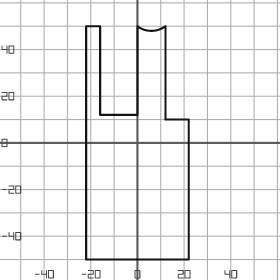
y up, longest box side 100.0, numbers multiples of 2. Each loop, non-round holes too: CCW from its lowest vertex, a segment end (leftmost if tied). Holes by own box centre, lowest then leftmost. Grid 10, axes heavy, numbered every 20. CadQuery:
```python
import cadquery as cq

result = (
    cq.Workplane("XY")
    .moveTo(-22.0, -50.0)
    .lineTo(22.0, -50.0)
    .lineTo(22.0, 10.0)
    .lineTo(12.0, 10.0)
    .lineTo(12.0, 50.0)
    .threePointArc((6.0, 48.0), (0.0, 50.0))
    .lineTo(0.0, 12.0)
    .lineTo(-16.0, 12.0)
    .lineTo(-16.0, 50.0)
    .lineTo(-22.0, 50.0)
    .close()
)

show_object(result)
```